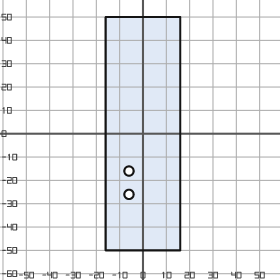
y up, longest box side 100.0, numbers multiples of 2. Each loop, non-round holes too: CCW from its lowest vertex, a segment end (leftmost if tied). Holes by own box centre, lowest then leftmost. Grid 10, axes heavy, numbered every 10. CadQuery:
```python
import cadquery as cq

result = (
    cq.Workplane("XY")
    .moveTo(-16.0, -50.0)
    .lineTo(16.0, -50.0)
    .lineTo(16.0, 50.0)
    .lineTo(-16.0, 50.0)
    .close()
    .moveTo(-6.0, -26.0)
    .circle(2.0)
    .moveTo(-6.0, -16.0)
    .circle(2.0)
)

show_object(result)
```